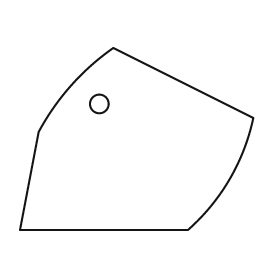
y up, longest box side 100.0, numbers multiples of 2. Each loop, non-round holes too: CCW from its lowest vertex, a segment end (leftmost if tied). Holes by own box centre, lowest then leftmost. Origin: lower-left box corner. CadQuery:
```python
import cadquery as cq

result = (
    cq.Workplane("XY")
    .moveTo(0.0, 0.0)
    .lineTo(72.0, 0.0)
    .threePointArc((90.0, 22.0), (100.0, 48.0))
    .lineTo(40.0, 78.0)
    .threePointArc((22.0, 62.0), (8.0, 42.0))
    .close()
    .moveTo(34.0, 54.0)
    .circle(4.0)
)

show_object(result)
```